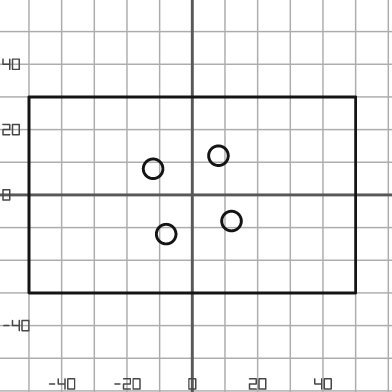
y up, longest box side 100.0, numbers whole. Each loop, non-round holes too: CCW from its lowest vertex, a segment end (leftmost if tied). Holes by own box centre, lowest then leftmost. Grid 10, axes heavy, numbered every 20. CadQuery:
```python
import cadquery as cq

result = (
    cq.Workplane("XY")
    .moveTo(-50.0, -30.0)
    .lineTo(50.0, -30.0)
    .lineTo(50.0, 30.0)
    .lineTo(-50.0, 30.0)
    .close()
    .moveTo(-8.0, -12.0)
    .circle(3.0)
    .moveTo(12.0, -8.0)
    .circle(3.0)
    .moveTo(-12.0, 8.0)
    .circle(3.0)
    .moveTo(8.0, 12.0)
    .circle(3.0)
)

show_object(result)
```